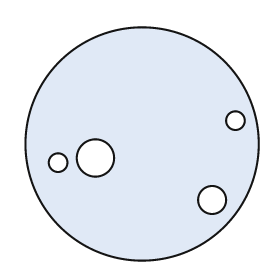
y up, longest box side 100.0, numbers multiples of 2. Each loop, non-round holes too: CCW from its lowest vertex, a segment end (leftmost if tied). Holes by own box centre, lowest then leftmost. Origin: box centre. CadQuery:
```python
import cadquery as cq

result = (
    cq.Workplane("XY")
    .moveTo(0.0, 0.0)
    .circle(50.0)
    .moveTo(30.0, -24.0)
    .circle(6.0)
    .moveTo(-36.0, -8.0)
    .circle(4.0)
    .moveTo(-20.0, -6.0)
    .circle(8.0)
    .moveTo(40.0, 10.0)
    .circle(4.0)
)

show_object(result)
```